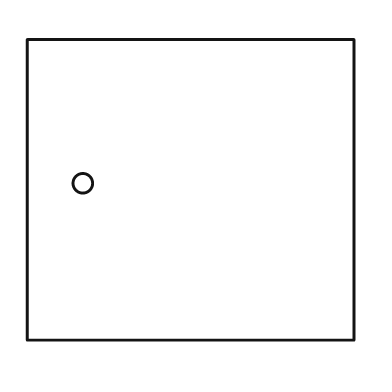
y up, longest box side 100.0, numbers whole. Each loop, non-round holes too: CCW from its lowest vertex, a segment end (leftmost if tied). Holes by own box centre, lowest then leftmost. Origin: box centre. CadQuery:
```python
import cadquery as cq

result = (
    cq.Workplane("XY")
    .moveTo(-50.0, -46.0)
    .lineTo(50.0, -46.0)
    .lineTo(50.0, 46.0)
    .lineTo(-50.0, 46.0)
    .close()
    .moveTo(-33.0, 2.0)
    .circle(3.0)
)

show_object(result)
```